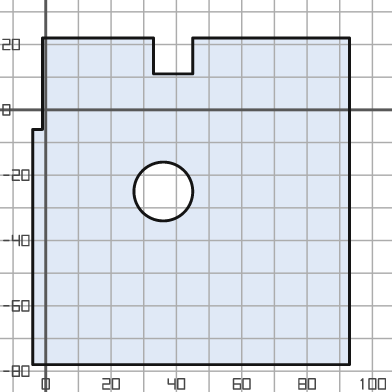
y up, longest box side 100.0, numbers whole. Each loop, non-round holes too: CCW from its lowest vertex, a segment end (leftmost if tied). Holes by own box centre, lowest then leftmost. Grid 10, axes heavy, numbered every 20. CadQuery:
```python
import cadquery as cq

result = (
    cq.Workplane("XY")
    .moveTo(-4.0, -78.0)
    .lineTo(93.0, -78.0)
    .lineTo(93.0, 22.0)
    .lineTo(45.0, 22.0)
    .lineTo(45.0, 11.0)
    .lineTo(33.0, 11.0)
    .lineTo(33.0, 22.0)
    .lineTo(-1.0, 22.0)
    .lineTo(-1.0, -6.0)
    .lineTo(-4.0, -6.0)
    .close()
    .moveTo(36.0, -25.0)
    .circle(9.0)
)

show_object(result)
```